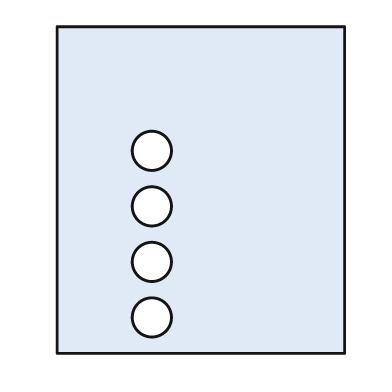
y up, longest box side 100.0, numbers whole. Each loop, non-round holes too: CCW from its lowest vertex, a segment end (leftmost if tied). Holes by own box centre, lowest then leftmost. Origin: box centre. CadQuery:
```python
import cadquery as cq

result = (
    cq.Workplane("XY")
    .moveTo(-44.0, -50.0)
    .lineTo(44.0, -50.0)
    .lineTo(44.0, 50.0)
    .lineTo(-44.0, 50.0)
    .close()
    .moveTo(-15.0, -39.0)
    .circle(6.0)
    .moveTo(-15.0, -22.0)
    .circle(6.0)
    .moveTo(-15.0, -5.0)
    .circle(6.0)
    .moveTo(-15.0, 12.0)
    .circle(6.0)
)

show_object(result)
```